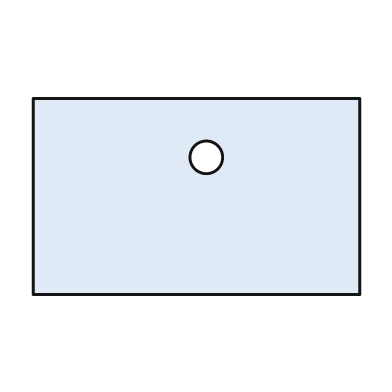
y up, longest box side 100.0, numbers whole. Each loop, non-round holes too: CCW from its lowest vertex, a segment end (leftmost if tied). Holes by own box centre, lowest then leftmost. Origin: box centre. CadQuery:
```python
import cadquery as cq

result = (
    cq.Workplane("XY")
    .moveTo(-50.0, -30.0)
    .lineTo(50.0, -30.0)
    .lineTo(50.0, 30.0)
    .lineTo(-50.0, 30.0)
    .close()
    .moveTo(3.0, 12.0)
    .circle(5.0)
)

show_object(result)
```